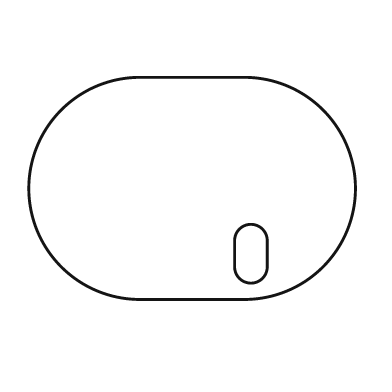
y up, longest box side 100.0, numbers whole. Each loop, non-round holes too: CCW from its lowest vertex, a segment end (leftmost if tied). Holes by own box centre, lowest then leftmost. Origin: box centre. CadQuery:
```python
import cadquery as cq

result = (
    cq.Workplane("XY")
    .moveTo(-16.0, -34.0)
    .lineTo(16.0, -34.0)
    .threePointArc((50.0, 0.0), (16.0, 34.0))
    .lineTo(-16.0, 34.0)
    .threePointArc((-50.0, 0.0), (-16.0, -34.0))
    .close()
    .moveTo(13.0, -24.0)
    .threePointArc((18.0, -29.0), (23.0, -24.0))
    .lineTo(23.0, -16.0)
    .threePointArc((18.0, -11.0), (13.0, -16.0))
    .close()
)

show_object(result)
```